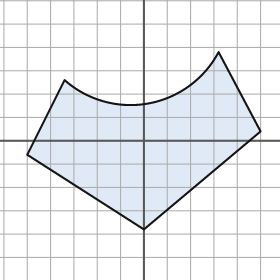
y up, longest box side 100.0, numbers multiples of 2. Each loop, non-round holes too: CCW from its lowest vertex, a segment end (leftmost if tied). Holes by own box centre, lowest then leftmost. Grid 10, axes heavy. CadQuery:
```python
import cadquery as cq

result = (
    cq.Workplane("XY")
    .moveTo(0.0, -38.0)
    .lineTo(50.0, 4.0)
    .lineTo(32.0, 38.0)
    .threePointArc((2.0, 16.0), (-34.0, 26.0))
    .lineTo(-50.0, -6.0)
    .close()
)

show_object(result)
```